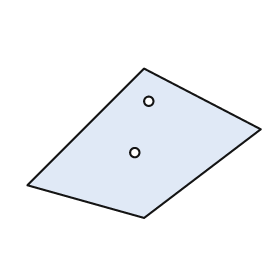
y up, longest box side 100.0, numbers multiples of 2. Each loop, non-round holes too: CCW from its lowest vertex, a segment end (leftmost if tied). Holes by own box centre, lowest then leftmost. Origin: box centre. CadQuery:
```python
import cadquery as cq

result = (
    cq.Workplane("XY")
    .moveTo(0.0, -32.0)
    .lineTo(50.0, 6.0)
    .lineTo(0.0, 32.0)
    .lineTo(-50.0, -18.0)
    .close()
    .moveTo(-4.0, -4.0)
    .circle(2.0)
    .moveTo(2.0, 18.0)
    .circle(2.0)
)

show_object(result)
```